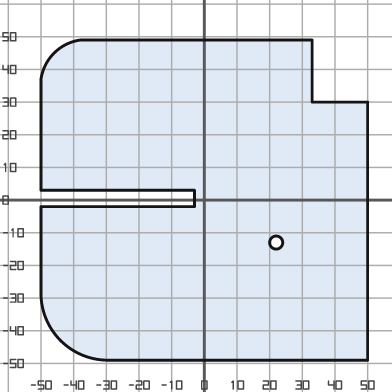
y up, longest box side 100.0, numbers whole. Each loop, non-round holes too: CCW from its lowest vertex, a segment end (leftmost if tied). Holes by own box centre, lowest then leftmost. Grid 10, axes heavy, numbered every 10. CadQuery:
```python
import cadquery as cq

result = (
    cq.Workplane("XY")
    .moveTo(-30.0, -49.0)
    .lineTo(50.0, -49.0)
    .lineTo(50.0, 30.0)
    .lineTo(33.0, 30.0)
    .lineTo(33.0, 49.0)
    .lineTo(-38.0, 49.0)
    .threePointArc((-46.0, 45.0), (-50.0, 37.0))
    .lineTo(-50.0, 3.0)
    .lineTo(-3.0, 3.0)
    .lineTo(-3.0, -2.0)
    .lineTo(-50.0, -2.0)
    .lineTo(-50.0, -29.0)
    .threePointArc((-44.0, -43.0), (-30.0, -49.0))
    .close()
    .moveTo(22.0, -13.0)
    .circle(2.0)
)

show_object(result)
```